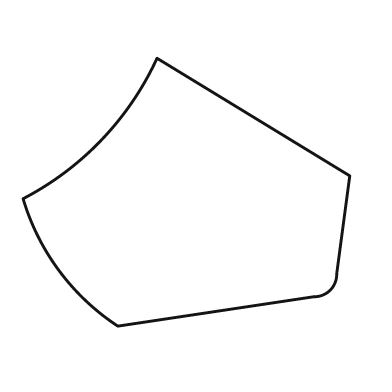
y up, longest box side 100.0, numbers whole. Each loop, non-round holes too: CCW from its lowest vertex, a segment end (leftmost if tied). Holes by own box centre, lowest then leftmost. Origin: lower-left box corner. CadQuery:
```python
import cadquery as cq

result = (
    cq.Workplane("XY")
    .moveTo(29.0, 0.0)
    .lineTo(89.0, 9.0)
    .threePointArc((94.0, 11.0), (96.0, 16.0))
    .lineTo(100.0, 46.0)
    .lineTo(41.0, 82.0)
    .threePointArc((24.0, 57.0), (0.0, 39.0))
    .threePointArc((11.0, 17.0), (29.0, 0.0))
    .close()
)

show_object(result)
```